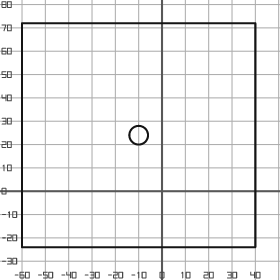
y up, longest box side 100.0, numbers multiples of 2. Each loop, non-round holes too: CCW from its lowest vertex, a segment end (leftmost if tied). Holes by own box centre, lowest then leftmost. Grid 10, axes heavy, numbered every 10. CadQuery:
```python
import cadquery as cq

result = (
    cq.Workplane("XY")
    .moveTo(-60.0, -24.0)
    .lineTo(40.0, -24.0)
    .lineTo(40.0, 72.0)
    .lineTo(-60.0, 72.0)
    .close()
    .moveTo(-10.0, 24.0)
    .circle(4.0)
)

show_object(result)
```